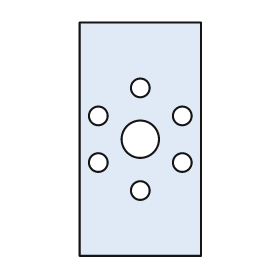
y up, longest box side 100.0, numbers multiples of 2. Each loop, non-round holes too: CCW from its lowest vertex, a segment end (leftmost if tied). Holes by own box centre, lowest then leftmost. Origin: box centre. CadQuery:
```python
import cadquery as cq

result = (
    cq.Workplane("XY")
    .moveTo(-26.0, -50.0)
    .lineTo(26.0, -50.0)
    .lineTo(26.0, 50.0)
    .lineTo(-26.0, 50.0)
    .close()
    .moveTo(0.0, -22.0)
    .circle(4.0)
    .moveTo(-18.0, -10.0)
    .circle(4.0)
    .moveTo(18.0, -10.0)
    .circle(4.0)
    .moveTo(0.0, 0.0)
    .circle(8.0)
    .moveTo(-18.0, 10.0)
    .circle(4.0)
    .moveTo(18.0, 10.0)
    .circle(4.0)
    .moveTo(0.0, 22.0)
    .circle(4.0)
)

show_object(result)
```